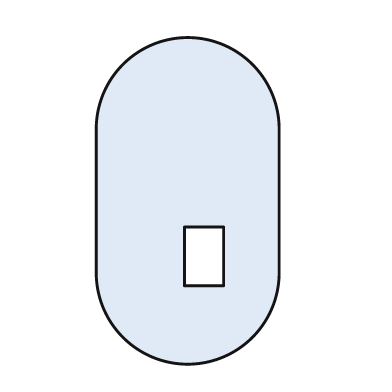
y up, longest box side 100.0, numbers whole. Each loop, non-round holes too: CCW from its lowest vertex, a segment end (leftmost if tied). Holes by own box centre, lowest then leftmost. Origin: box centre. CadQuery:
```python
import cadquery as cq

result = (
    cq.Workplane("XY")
    .moveTo(-28.0, -22.0)
    .threePointArc((0.0, -50.0), (28.0, -22.0))
    .lineTo(28.0, 22.0)
    .threePointArc((0.0, 50.0), (-28.0, 22.0))
    .close()
    .moveTo(-1.0, -26.0)
    .lineTo(11.0, -26.0)
    .lineTo(11.0, -8.0)
    .lineTo(-1.0, -8.0)
    .close()
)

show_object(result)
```